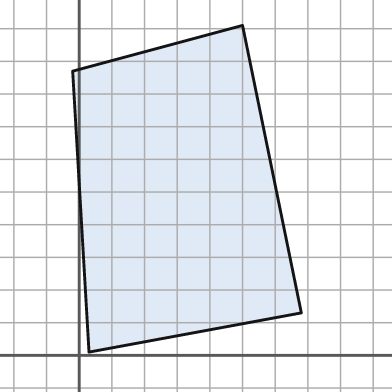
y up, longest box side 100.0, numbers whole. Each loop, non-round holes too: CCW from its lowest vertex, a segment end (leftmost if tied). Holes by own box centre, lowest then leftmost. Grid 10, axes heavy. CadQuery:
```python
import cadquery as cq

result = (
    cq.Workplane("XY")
    .moveTo(3.0, 1.0)
    .lineTo(68.0, 13.0)
    .lineTo(50.0, 101.0)
    .lineTo(-2.0, 87.0)
    .close()
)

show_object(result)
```